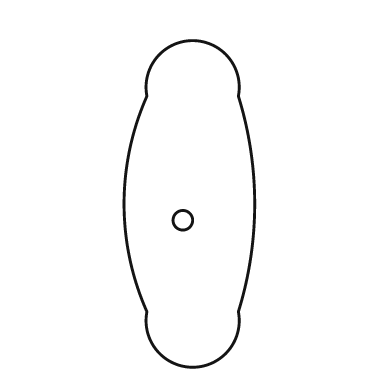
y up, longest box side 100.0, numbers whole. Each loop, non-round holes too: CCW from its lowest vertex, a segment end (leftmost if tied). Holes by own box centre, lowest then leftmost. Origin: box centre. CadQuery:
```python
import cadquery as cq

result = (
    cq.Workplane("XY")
    .moveTo(-13.0, -33.0)
    .threePointArc((1.0, -50.0), (15.0, -33.0))
    .threePointArc((20.0, 0.0), (15.0, 33.0))
    .threePointArc((1.0, 50.0), (-13.0, 33.0))
    .threePointArc((-20.0, 0.0), (-13.0, -33.0))
    .close()
    .moveTo(-2.0, -5.0)
    .circle(3.0)
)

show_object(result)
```